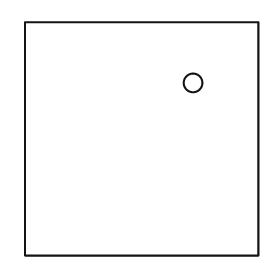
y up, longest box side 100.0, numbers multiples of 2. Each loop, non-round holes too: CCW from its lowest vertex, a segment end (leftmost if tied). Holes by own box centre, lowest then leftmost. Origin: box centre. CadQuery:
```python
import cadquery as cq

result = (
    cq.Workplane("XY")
    .moveTo(-50.0, -50.0)
    .lineTo(50.0, -50.0)
    .lineTo(50.0, 50.0)
    .lineTo(-50.0, 50.0)
    .close()
    .moveTo(22.0, 24.0)
    .circle(4.0)
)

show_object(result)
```